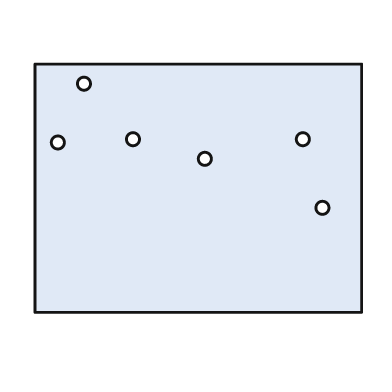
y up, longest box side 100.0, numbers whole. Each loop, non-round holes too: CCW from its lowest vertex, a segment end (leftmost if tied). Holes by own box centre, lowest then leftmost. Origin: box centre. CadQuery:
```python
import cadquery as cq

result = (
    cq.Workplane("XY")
    .moveTo(-50.0, -38.0)
    .lineTo(50.0, -38.0)
    .lineTo(50.0, 38.0)
    .lineTo(-50.0, 38.0)
    .close()
    .moveTo(38.0, -6.0)
    .circle(2.0)
    .moveTo(2.0, 9.0)
    .circle(2.0)
    .moveTo(-43.0, 14.0)
    .circle(2.0)
    .moveTo(-20.0, 15.0)
    .circle(2.0)
    .moveTo(32.0, 15.0)
    .circle(2.0)
    .moveTo(-35.0, 32.0)
    .circle(2.0)
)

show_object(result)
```